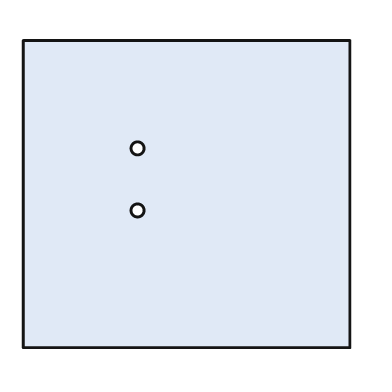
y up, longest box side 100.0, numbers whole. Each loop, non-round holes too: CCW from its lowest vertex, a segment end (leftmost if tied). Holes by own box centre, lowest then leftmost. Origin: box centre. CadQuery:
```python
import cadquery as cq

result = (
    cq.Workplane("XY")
    .moveTo(-50.0, -47.0)
    .lineTo(50.0, -47.0)
    .lineTo(50.0, 47.0)
    .lineTo(-50.0, 47.0)
    .close()
    .moveTo(-15.0, -5.0)
    .circle(2.0)
    .moveTo(-15.0, 14.0)
    .circle(2.0)
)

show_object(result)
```